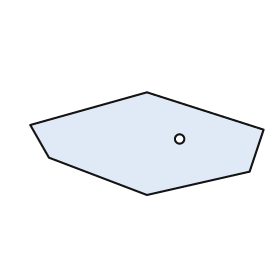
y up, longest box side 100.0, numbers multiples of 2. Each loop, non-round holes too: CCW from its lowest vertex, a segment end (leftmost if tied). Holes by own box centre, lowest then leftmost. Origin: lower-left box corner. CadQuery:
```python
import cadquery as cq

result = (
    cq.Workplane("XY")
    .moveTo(50.0, 0.0)
    .lineTo(94.0, 10.0)
    .lineTo(100.0, 28.0)
    .lineTo(50.0, 44.0)
    .lineTo(0.0, 30.0)
    .lineTo(8.0, 16.0)
    .close()
    .moveTo(64.0, 24.0)
    .circle(2.0)
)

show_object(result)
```